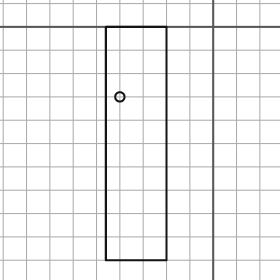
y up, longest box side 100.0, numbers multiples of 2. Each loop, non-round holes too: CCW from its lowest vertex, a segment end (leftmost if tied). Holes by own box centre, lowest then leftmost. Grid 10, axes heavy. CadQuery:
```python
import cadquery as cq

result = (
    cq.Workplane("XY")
    .moveTo(-46.0, -100.0)
    .lineTo(-20.0, -100.0)
    .lineTo(-20.0, 0.0)
    .lineTo(-46.0, 0.0)
    .close()
    .moveTo(-40.0, -30.0)
    .circle(2.0)
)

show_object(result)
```